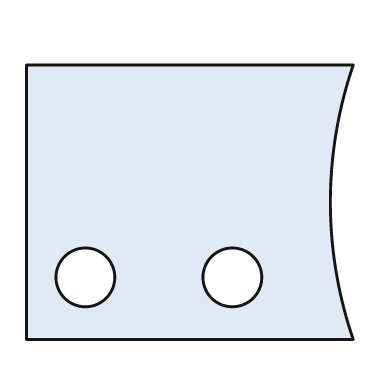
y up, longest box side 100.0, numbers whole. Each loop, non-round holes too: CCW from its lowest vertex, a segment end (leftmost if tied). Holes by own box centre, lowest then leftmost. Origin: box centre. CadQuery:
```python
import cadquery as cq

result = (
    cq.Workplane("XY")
    .moveTo(-50.0, -42.0)
    .lineTo(50.0, -42.0)
    .threePointArc((43.0, 0.0), (50.0, 42.0))
    .lineTo(-50.0, 42.0)
    .close()
    .moveTo(-32.0, -23.0)
    .circle(9.0)
    .moveTo(13.0, -23.0)
    .circle(9.0)
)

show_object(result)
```